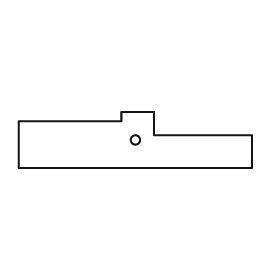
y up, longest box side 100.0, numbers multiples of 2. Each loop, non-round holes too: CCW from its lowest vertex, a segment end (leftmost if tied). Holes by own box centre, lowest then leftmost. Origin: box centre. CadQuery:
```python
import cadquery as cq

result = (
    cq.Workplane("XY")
    .moveTo(-50.0, -12.0)
    .lineTo(50.0, -12.0)
    .lineTo(50.0, 2.0)
    .lineTo(8.0, 2.0)
    .lineTo(8.0, 12.0)
    .lineTo(-6.0, 12.0)
    .lineTo(-6.0, 8.0)
    .lineTo(-50.0, 8.0)
    .close()
    .moveTo(0.0, 0.0)
    .circle(2.0)
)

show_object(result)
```